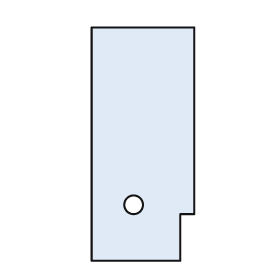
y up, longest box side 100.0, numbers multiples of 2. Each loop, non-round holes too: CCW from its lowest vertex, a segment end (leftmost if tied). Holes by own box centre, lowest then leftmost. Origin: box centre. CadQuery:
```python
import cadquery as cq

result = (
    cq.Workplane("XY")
    .moveTo(-22.0, -50.0)
    .lineTo(16.0, -50.0)
    .lineTo(16.0, -30.0)
    .lineTo(22.0, -30.0)
    .lineTo(22.0, 50.0)
    .lineTo(-22.0, 50.0)
    .close()
    .moveTo(-4.0, -26.0)
    .circle(4.0)
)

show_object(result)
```